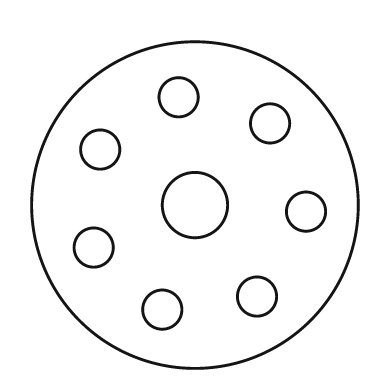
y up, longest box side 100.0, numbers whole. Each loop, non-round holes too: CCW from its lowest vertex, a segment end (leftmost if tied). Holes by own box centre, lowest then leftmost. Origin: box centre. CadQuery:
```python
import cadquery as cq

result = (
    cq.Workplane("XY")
    .moveTo(0.0, 0.0)
    .circle(50.0)
    .moveTo(-10.0, -32.0)
    .circle(6.0)
    .moveTo(19.0, -28.0)
    .circle(6.0)
    .moveTo(-31.0, -13.0)
    .circle(6.0)
    .moveTo(34.0, -2.0)
    .circle(6.0)
    .moveTo(0.0, 0.0)
    .circle(10.0)
    .moveTo(-29.0, 17.0)
    .circle(6.0)
    .moveTo(23.0, 25.0)
    .circle(6.0)
    .moveTo(-5.0, 33.0)
    .circle(6.0)
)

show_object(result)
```